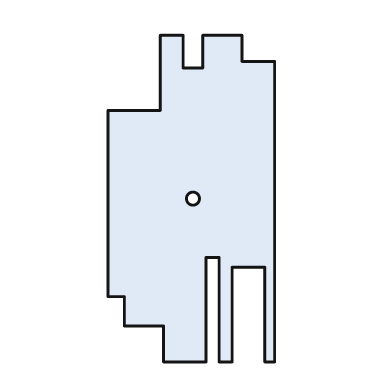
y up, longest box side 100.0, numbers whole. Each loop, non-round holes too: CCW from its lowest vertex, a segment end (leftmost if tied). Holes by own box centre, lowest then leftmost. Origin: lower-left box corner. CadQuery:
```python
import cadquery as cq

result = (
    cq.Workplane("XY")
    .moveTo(17.0, 0.0)
    .lineTo(30.0, 0.0)
    .lineTo(30.0, 32.0)
    .lineTo(34.0, 32.0)
    .lineTo(34.0, 0.0)
    .lineTo(38.0, 0.0)
    .lineTo(38.0, 29.0)
    .lineTo(48.0, 29.0)
    .lineTo(48.0, 0.0)
    .lineTo(51.0, 0.0)
    .lineTo(51.0, 92.0)
    .lineTo(41.0, 92.0)
    .lineTo(41.0, 100.0)
    .lineTo(29.0, 100.0)
    .lineTo(29.0, 90.0)
    .lineTo(23.0, 90.0)
    .lineTo(23.0, 100.0)
    .lineTo(16.0, 100.0)
    .lineTo(16.0, 77.0)
    .lineTo(0.0, 77.0)
    .lineTo(0.0, 20.0)
    .lineTo(5.0, 20.0)
    .lineTo(5.0, 11.0)
    .lineTo(17.0, 11.0)
    .close()
    .moveTo(26.0, 50.0)
    .circle(2.0)
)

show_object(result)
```